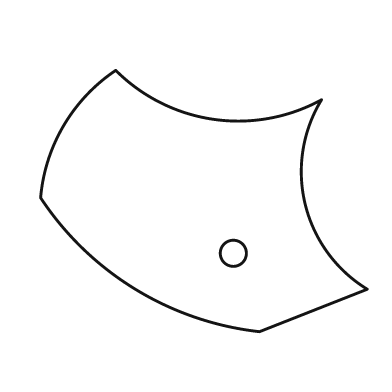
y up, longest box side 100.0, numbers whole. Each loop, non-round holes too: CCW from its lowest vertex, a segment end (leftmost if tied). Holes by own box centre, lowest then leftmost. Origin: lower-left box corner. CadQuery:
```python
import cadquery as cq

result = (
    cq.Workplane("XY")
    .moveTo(67.0, 0.0)
    .lineTo(100.0, 13.0)
    .threePointArc((81.0, 39.0), (86.0, 71.0))
    .threePointArc((53.0, 65.0), (23.0, 80.0))
    .threePointArc((7.0, 63.0), (0.0, 41.0))
    .threePointArc((29.0, 13.0), (67.0, 0.0))
    .close()
    .moveTo(59.0, 24.0)
    .circle(4.0)
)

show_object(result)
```